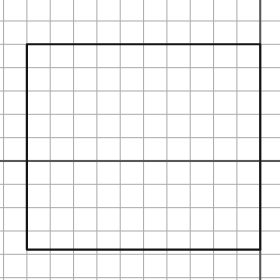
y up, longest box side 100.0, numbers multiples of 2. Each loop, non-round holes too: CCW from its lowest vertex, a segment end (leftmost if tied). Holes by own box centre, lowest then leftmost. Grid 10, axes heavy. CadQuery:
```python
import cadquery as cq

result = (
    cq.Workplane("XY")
    .moveTo(-100.0, -38.0)
    .lineTo(0.0, -38.0)
    .lineTo(0.0, 50.0)
    .lineTo(-100.0, 50.0)
    .close()
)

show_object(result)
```